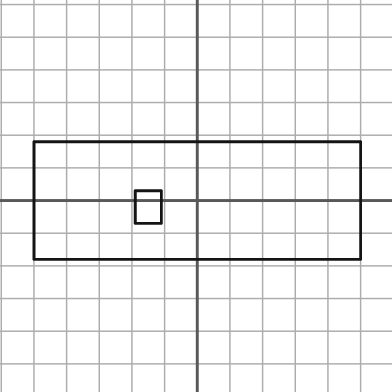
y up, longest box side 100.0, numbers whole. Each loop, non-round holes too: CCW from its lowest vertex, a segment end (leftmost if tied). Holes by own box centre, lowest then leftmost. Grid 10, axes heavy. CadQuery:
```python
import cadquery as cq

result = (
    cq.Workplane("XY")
    .moveTo(-50.0, -18.0)
    .lineTo(50.0, -18.0)
    .lineTo(50.0, 18.0)
    .lineTo(-50.0, 18.0)
    .close()
    .moveTo(-19.0, -7.0)
    .lineTo(-11.0, -7.0)
    .lineTo(-11.0, 3.0)
    .lineTo(-19.0, 3.0)
    .close()
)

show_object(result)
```